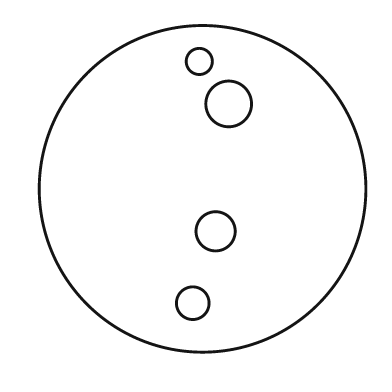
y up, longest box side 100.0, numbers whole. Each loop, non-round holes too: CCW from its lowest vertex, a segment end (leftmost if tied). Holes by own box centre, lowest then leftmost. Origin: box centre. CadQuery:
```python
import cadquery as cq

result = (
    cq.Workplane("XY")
    .moveTo(0.0, 0.0)
    .circle(50.0)
    .moveTo(-3.0, -35.0)
    .circle(5.0)
    .moveTo(4.0, -13.0)
    .circle(6.0)
    .moveTo(8.0, 26.0)
    .circle(7.0)
    .moveTo(-1.0, 39.0)
    .circle(4.0)
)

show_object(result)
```